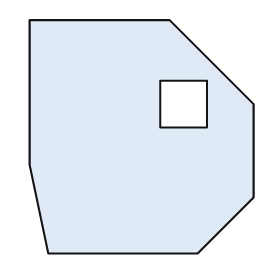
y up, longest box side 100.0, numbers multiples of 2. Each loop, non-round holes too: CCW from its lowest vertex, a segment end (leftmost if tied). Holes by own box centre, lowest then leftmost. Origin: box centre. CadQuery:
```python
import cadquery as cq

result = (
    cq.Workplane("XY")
    .moveTo(-40.0, -50.0)
    .lineTo(24.0, -50.0)
    .lineTo(48.0, -26.0)
    .lineTo(48.0, 14.0)
    .lineTo(12.0, 50.0)
    .lineTo(-48.0, 50.0)
    .lineTo(-48.0, -12.0)
    .close()
    .moveTo(8.0, 4.0)
    .lineTo(28.0, 4.0)
    .lineTo(28.0, 24.0)
    .lineTo(8.0, 24.0)
    .close()
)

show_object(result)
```